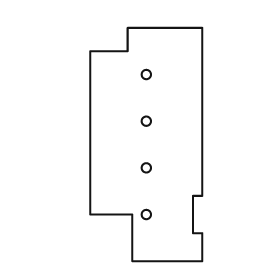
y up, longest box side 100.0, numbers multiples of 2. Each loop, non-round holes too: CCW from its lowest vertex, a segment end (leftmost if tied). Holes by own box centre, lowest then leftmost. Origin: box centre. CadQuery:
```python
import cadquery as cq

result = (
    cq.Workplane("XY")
    .moveTo(-6.0, -50.0)
    .lineTo(24.0, -50.0)
    .lineTo(24.0, -38.0)
    .lineTo(20.0, -38.0)
    .lineTo(20.0, -22.0)
    .lineTo(24.0, -22.0)
    .lineTo(24.0, 50.0)
    .lineTo(-8.0, 50.0)
    .lineTo(-8.0, 40.0)
    .lineTo(-24.0, 40.0)
    .lineTo(-24.0, -30.0)
    .lineTo(-6.0, -30.0)
    .close()
    .moveTo(0.0, -30.0)
    .circle(2.0)
    .moveTo(0.0, -10.0)
    .circle(2.0)
    .moveTo(0.0, 10.0)
    .circle(2.0)
    .moveTo(0.0, 30.0)
    .circle(2.0)
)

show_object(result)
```